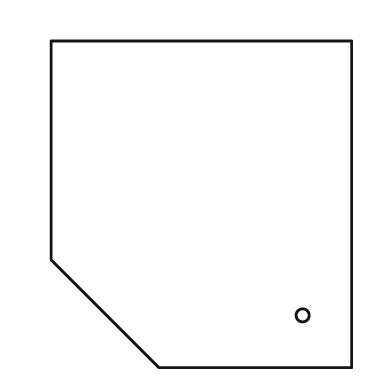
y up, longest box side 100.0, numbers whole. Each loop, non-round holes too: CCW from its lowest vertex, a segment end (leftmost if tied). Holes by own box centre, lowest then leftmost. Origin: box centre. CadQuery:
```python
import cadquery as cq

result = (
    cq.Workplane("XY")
    .moveTo(-13.0, -50.0)
    .lineTo(46.0, -50.0)
    .lineTo(46.0, 50.0)
    .lineTo(-46.0, 50.0)
    .lineTo(-46.0, -17.0)
    .close()
    .moveTo(31.0, -34.0)
    .circle(2.0)
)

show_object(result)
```